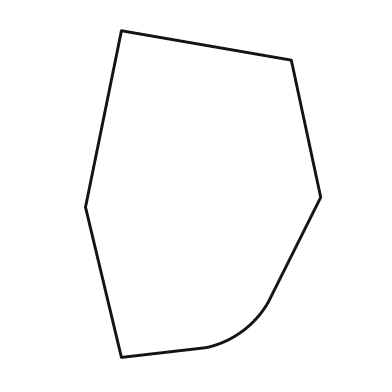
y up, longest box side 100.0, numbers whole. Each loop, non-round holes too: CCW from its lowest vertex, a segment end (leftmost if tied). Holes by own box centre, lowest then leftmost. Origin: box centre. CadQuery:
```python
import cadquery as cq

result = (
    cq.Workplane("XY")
    .moveTo(-25.0, -50.0)
    .lineTo(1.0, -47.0)
    .threePointArc((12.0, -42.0), (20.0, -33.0))
    .lineTo(36.0, -1.0)
    .lineTo(27.0, 41.0)
    .lineTo(-25.0, 50.0)
    .lineTo(-36.0, -4.0)
    .close()
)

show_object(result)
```